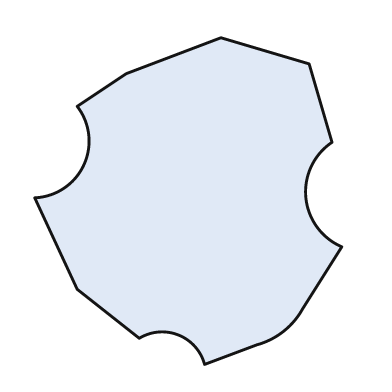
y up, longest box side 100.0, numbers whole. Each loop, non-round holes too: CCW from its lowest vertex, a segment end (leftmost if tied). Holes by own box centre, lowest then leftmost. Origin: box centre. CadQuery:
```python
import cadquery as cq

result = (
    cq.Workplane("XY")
    .moveTo(5.0, -50.0)
    .lineTo(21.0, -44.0)
    .threePointArc((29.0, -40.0), (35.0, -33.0))
    .lineTo(47.0, -14.0)
    .threePointArc((36.0, 1.0), (44.0, 18.0))
    .lineTo(37.0, 42.0)
    .lineTo(10.0, 50.0)
    .lineTo(-19.0, 39.0)
    .lineTo(-34.0, 29.0)
    .threePointArc((-32.0, 11.0), (-47.0, 1.0))
    .lineTo(-34.0, -27.0)
    .lineTo(-15.0, -42.0)
    .threePointArc((-3.0, -41.0), (5.0, -50.0))
    .close()
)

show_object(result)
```